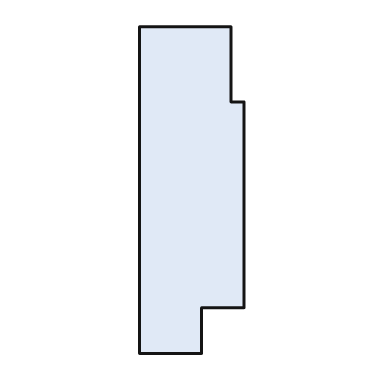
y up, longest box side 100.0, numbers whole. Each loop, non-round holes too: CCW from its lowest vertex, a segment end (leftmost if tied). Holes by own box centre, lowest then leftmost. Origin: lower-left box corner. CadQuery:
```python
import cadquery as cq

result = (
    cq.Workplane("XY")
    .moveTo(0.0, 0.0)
    .lineTo(19.0, 0.0)
    .lineTo(19.0, 14.0)
    .lineTo(32.0, 14.0)
    .lineTo(32.0, 77.0)
    .lineTo(28.0, 77.0)
    .lineTo(28.0, 100.0)
    .lineTo(0.0, 100.0)
    .close()
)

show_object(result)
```